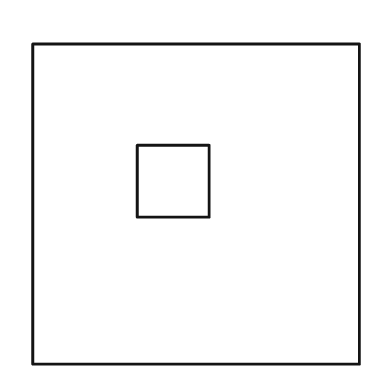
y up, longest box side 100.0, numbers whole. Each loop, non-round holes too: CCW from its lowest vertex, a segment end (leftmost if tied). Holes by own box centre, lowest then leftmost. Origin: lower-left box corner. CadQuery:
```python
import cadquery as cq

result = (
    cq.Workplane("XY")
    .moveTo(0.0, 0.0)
    .lineTo(100.0, 0.0)
    .lineTo(100.0, 98.0)
    .lineTo(0.0, 98.0)
    .close()
    .moveTo(32.0, 45.0)
    .lineTo(54.0, 45.0)
    .lineTo(54.0, 67.0)
    .lineTo(32.0, 67.0)
    .close()
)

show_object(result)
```